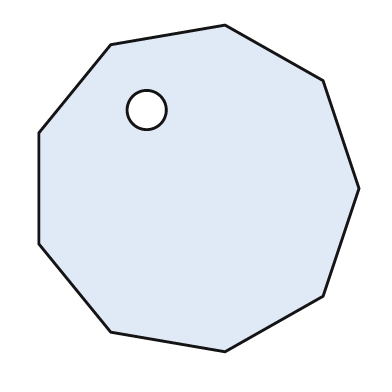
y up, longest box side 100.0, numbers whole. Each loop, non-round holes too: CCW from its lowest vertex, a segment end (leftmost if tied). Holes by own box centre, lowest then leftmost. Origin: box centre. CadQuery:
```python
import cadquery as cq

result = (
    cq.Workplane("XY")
    .moveTo(8.0, -50.0)
    .lineTo(38.0, -33.0)
    .lineTo(49.0, 0.0)
    .lineTo(38.0, 33.0)
    .lineTo(8.0, 50.0)
    .lineTo(-27.0, 44.0)
    .lineTo(-49.0, 17.0)
    .lineTo(-49.0, -17.0)
    .lineTo(-27.0, -44.0)
    .close()
    .moveTo(-16.0, 24.0)
    .circle(6.0)
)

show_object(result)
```